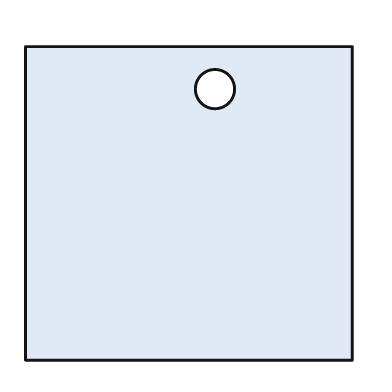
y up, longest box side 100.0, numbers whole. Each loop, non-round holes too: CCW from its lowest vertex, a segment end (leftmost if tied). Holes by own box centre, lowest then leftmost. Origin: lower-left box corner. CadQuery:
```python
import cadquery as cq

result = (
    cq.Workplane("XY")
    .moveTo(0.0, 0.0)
    .lineTo(100.0, 0.0)
    .lineTo(100.0, 96.0)
    .lineTo(0.0, 96.0)
    .close()
    .moveTo(58.0, 83.0)
    .circle(6.0)
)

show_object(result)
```